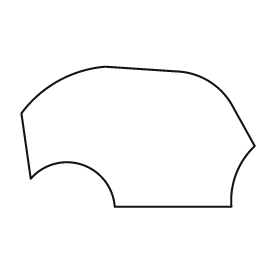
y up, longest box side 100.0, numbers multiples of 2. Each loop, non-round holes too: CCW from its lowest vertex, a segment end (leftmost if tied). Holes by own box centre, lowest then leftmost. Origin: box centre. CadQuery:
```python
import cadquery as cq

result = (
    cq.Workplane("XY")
    .moveTo(-10.0, -30.0)
    .lineTo(40.0, -30.0)
    .threePointArc((42.0, -16.0), (50.0, -4.0))
    .lineTo(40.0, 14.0)
    .threePointArc((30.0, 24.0), (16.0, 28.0))
    .lineTo(-14.0, 30.0)
    .threePointArc((-34.0, 24.0), (-50.0, 10.0))
    .lineTo(-46.0, -18.0)
    .threePointArc((-24.0, -12.0), (-10.0, -30.0))
    .close()
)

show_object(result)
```